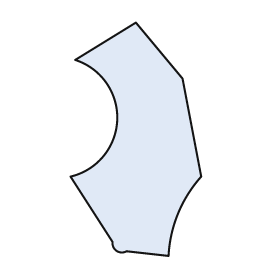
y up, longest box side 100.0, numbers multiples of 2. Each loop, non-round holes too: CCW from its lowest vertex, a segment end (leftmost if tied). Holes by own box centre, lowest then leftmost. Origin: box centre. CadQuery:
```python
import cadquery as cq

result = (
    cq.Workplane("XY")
    .moveTo(14.0, -50.0)
    .threePointArc((18.0, -32.0), (28.0, -16.0))
    .lineTo(20.0, 26.0)
    .lineTo(0.0, 50.0)
    .lineTo(-26.0, 34.0)
    .threePointArc((-8.0, 8.0), (-28.0, -16.0))
    .lineTo(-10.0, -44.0)
    .threePointArc((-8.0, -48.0), (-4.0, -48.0))
    .close()
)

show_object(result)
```